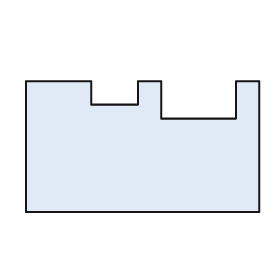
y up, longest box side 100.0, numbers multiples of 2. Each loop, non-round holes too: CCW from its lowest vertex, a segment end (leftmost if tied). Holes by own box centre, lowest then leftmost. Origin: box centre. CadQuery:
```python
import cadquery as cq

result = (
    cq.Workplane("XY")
    .moveTo(-50.0, -28.0)
    .lineTo(50.0, -28.0)
    .lineTo(50.0, 28.0)
    .lineTo(40.0, 28.0)
    .lineTo(40.0, 12.0)
    .lineTo(8.0, 12.0)
    .lineTo(8.0, 28.0)
    .lineTo(-2.0, 28.0)
    .lineTo(-2.0, 18.0)
    .lineTo(-22.0, 18.0)
    .lineTo(-22.0, 28.0)
    .lineTo(-50.0, 28.0)
    .close()
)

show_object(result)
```